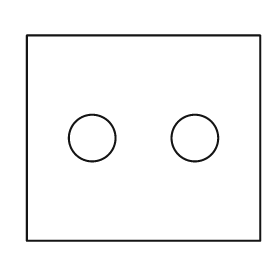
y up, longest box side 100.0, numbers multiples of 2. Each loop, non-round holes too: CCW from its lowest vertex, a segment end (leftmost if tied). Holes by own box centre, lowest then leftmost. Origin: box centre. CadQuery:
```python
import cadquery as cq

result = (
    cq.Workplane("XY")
    .moveTo(-50.0, -44.0)
    .lineTo(50.0, -44.0)
    .lineTo(50.0, 44.0)
    .lineTo(-50.0, 44.0)
    .close()
    .moveTo(-22.0, 0.0)
    .circle(10.0)
    .moveTo(22.0, 0.0)
    .circle(10.0)
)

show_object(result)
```